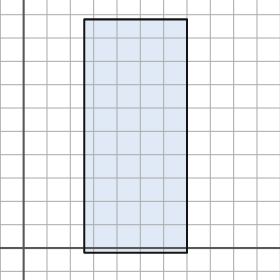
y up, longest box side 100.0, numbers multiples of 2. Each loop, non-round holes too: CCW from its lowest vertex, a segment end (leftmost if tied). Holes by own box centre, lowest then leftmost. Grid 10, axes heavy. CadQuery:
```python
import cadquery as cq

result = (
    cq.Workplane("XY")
    .moveTo(26.0, -2.0)
    .lineTo(70.0, -2.0)
    .lineTo(70.0, 98.0)
    .lineTo(26.0, 98.0)
    .close()
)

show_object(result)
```